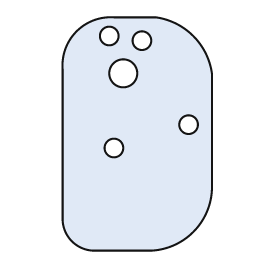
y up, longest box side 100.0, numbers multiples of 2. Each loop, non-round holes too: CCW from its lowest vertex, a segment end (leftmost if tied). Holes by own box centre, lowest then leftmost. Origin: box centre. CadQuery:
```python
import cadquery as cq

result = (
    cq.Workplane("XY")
    .moveTo(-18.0, -50.0)
    .lineTo(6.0, -50.0)
    .threePointArc((24.0, -42.0), (32.0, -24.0))
    .lineTo(32.0, 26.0)
    .threePointArc((24.0, 42.0), (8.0, 50.0))
    .lineTo(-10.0, 50.0)
    .threePointArc((-26.0, 44.0), (-32.0, 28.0))
    .lineTo(-32.0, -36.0)
    .threePointArc((-28.0, -46.0), (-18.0, -50.0))
    .close()
    .moveTo(-10.0, -6.0)
    .circle(4.0)
    .moveTo(22.0, 4.0)
    .circle(4.0)
    .moveTo(-6.0, 26.0)
    .circle(6.0)
    .moveTo(2.0, 40.0)
    .circle(4.0)
    .moveTo(-12.0, 42.0)
    .circle(4.0)
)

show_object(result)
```